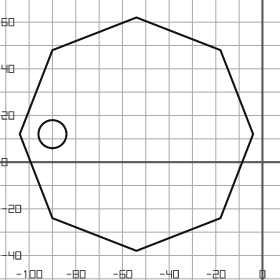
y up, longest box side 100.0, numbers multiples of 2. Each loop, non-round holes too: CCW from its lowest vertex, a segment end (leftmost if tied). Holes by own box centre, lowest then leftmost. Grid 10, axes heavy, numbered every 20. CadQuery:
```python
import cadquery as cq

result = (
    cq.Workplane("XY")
    .moveTo(-54.0, -38.0)
    .lineTo(-18.0, -24.0)
    .lineTo(-4.0, 12.0)
    .lineTo(-18.0, 48.0)
    .lineTo(-54.0, 62.0)
    .lineTo(-90.0, 48.0)
    .lineTo(-104.0, 12.0)
    .lineTo(-90.0, -24.0)
    .close()
    .moveTo(-90.0, 12.0)
    .circle(6.0)
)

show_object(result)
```